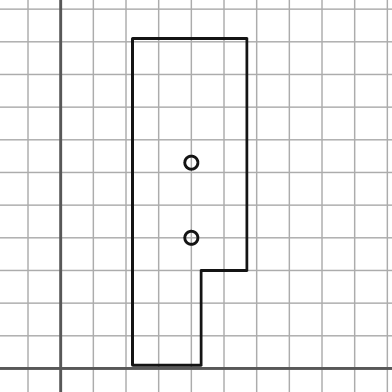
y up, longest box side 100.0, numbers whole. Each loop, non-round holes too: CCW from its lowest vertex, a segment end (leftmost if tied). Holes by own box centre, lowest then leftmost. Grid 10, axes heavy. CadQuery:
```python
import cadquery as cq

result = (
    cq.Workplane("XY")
    .moveTo(22.0, 1.0)
    .lineTo(43.0, 1.0)
    .lineTo(43.0, 30.0)
    .lineTo(57.0, 30.0)
    .lineTo(57.0, 101.0)
    .lineTo(22.0, 101.0)
    .close()
    .moveTo(40.0, 40.0)
    .circle(2.0)
    .moveTo(40.0, 63.0)
    .circle(2.0)
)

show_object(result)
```